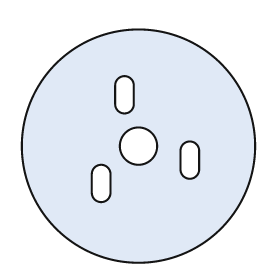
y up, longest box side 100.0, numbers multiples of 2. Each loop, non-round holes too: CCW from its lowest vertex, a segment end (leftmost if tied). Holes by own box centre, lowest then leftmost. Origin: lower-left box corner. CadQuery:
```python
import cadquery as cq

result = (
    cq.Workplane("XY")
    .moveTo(50.0, 50.0)
    .circle(50.0)
    .moveTo(30.0, 30.0)
    .threePointArc((34.0, 26.0), (38.0, 30.0))
    .lineTo(38.0, 38.0)
    .threePointArc((34.0, 42.0), (30.0, 38.0))
    .close()
    .moveTo(68.0, 40.0)
    .threePointArc((72.0, 36.0), (76.0, 40.0))
    .lineTo(76.0, 48.0)
    .threePointArc((72.0, 52.0), (68.0, 48.0))
    .close()
    .moveTo(50.0, 50.0)
    .circle(8.0)
    .moveTo(40.0, 68.0)
    .threePointArc((44.0, 64.0), (48.0, 68.0))
    .lineTo(48.0, 76.0)
    .threePointArc((44.0, 80.0), (40.0, 76.0))
    .close()
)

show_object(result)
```